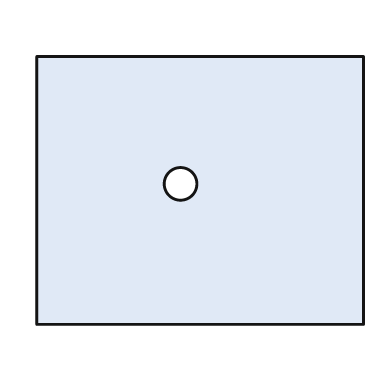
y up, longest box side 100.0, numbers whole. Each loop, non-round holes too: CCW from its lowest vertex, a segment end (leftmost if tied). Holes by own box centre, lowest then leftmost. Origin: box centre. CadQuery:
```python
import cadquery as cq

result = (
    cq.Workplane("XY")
    .moveTo(-50.0, -41.0)
    .lineTo(50.0, -41.0)
    .lineTo(50.0, 41.0)
    .lineTo(-50.0, 41.0)
    .close()
    .moveTo(-6.0, 2.0)
    .circle(5.0)
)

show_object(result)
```